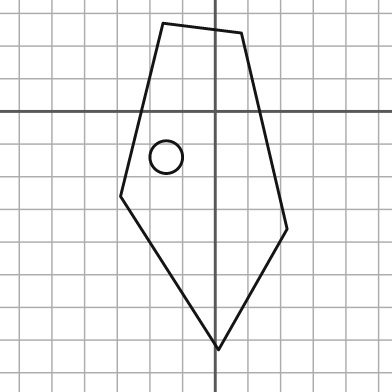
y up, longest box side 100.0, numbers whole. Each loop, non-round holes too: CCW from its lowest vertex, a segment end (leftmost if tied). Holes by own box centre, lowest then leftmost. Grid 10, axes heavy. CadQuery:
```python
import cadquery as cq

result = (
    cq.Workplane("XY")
    .moveTo(1.0, -73.0)
    .lineTo(22.0, -36.0)
    .lineTo(8.0, 24.0)
    .lineTo(-16.0, 27.0)
    .lineTo(-29.0, -26.0)
    .close()
    .moveTo(-15.0, -14.0)
    .circle(5.0)
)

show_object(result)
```